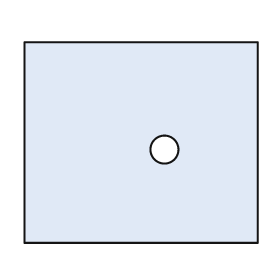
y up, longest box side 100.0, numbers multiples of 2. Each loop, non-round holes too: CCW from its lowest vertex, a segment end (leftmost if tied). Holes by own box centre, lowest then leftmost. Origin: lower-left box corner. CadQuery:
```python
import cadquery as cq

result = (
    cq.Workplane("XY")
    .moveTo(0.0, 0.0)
    .lineTo(100.0, 0.0)
    .lineTo(100.0, 86.0)
    .lineTo(0.0, 86.0)
    .close()
    .moveTo(60.0, 40.0)
    .circle(6.0)
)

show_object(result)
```